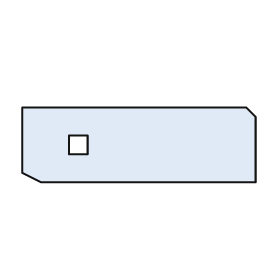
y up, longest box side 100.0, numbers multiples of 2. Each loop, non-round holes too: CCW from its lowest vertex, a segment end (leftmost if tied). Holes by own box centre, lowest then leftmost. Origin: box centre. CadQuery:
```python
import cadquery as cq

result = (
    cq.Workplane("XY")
    .moveTo(-42.0, -16.0)
    .lineTo(50.0, -16.0)
    .lineTo(50.0, 12.0)
    .lineTo(46.0, 16.0)
    .lineTo(-50.0, 16.0)
    .lineTo(-50.0, -12.0)
    .close()
    .moveTo(-30.0, -4.0)
    .lineTo(-22.0, -4.0)
    .lineTo(-22.0, 4.0)
    .lineTo(-30.0, 4.0)
    .close()
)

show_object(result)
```